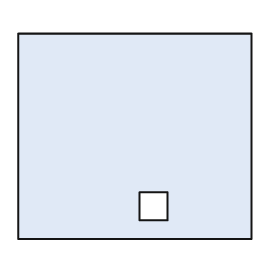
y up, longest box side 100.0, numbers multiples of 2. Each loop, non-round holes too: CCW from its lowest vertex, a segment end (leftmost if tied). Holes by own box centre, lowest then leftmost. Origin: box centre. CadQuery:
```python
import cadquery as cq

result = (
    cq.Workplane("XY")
    .moveTo(-50.0, -44.0)
    .lineTo(50.0, -44.0)
    .lineTo(50.0, 44.0)
    .lineTo(-50.0, 44.0)
    .close()
    .moveTo(2.0, -36.0)
    .lineTo(14.0, -36.0)
    .lineTo(14.0, -24.0)
    .lineTo(2.0, -24.0)
    .close()
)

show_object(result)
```